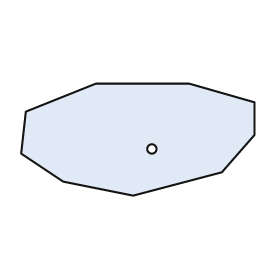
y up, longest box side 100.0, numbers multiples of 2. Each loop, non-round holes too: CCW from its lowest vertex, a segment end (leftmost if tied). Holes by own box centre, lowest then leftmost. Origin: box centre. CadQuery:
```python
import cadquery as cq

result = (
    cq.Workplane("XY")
    .moveTo(-2.0, -24.0)
    .lineTo(36.0, -14.0)
    .lineTo(50.0, 2.0)
    .lineTo(50.0, 16.0)
    .lineTo(22.0, 24.0)
    .lineTo(-18.0, 24.0)
    .lineTo(-48.0, 12.0)
    .lineTo(-50.0, -6.0)
    .lineTo(-32.0, -18.0)
    .close()
    .moveTo(6.0, -4.0)
    .circle(2.0)
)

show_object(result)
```